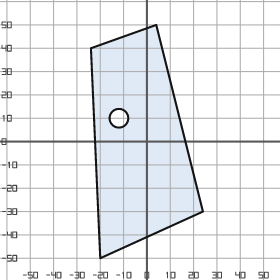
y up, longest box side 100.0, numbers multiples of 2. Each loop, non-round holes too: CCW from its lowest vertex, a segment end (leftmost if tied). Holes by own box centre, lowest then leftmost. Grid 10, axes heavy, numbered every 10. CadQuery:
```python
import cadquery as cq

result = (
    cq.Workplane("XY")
    .moveTo(-20.0, -50.0)
    .lineTo(24.0, -30.0)
    .lineTo(4.0, 50.0)
    .lineTo(-24.0, 40.0)
    .close()
    .moveTo(-12.0, 10.0)
    .circle(4.0)
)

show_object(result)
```